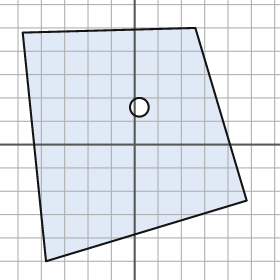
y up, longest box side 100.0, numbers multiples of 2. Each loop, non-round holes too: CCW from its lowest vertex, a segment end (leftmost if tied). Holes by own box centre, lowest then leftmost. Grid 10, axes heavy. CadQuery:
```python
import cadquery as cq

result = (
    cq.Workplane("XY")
    .moveTo(-38.0, -50.0)
    .lineTo(48.0, -24.0)
    .lineTo(26.0, 50.0)
    .lineTo(-48.0, 48.0)
    .close()
    .moveTo(2.0, 16.0)
    .circle(4.0)
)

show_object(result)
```